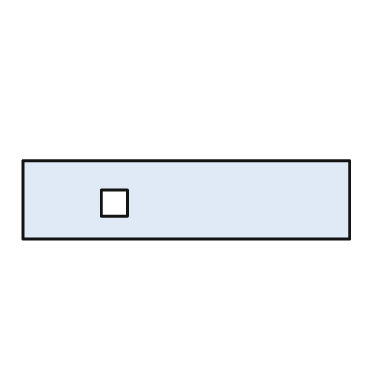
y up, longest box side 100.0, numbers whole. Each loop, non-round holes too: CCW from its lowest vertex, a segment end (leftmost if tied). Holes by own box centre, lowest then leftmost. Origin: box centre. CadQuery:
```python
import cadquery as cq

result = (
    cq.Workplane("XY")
    .moveTo(-50.0, -12.0)
    .lineTo(50.0, -12.0)
    .lineTo(50.0, 12.0)
    .lineTo(-50.0, 12.0)
    .close()
    .moveTo(-26.0, -5.0)
    .lineTo(-18.0, -5.0)
    .lineTo(-18.0, 3.0)
    .lineTo(-26.0, 3.0)
    .close()
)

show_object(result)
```